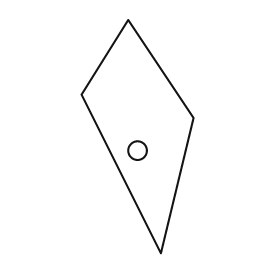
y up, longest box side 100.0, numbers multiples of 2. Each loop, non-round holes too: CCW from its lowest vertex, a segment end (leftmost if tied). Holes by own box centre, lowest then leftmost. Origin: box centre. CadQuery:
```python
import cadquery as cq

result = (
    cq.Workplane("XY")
    .moveTo(10.0, -50.0)
    .lineTo(24.0, 8.0)
    .lineTo(-4.0, 50.0)
    .lineTo(-24.0, 18.0)
    .close()
    .moveTo(0.0, -6.0)
    .circle(4.0)
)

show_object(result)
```